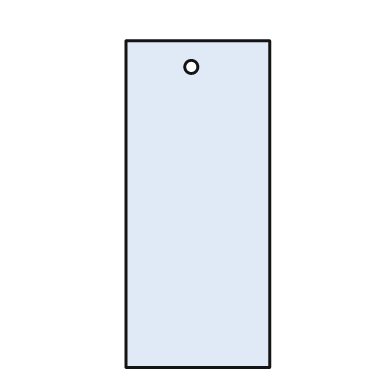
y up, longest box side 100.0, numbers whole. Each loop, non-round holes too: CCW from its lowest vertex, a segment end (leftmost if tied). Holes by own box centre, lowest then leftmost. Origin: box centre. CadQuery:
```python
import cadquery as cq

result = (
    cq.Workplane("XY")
    .moveTo(-22.0, -50.0)
    .lineTo(22.0, -50.0)
    .lineTo(22.0, 50.0)
    .lineTo(-22.0, 50.0)
    .close()
    .moveTo(-2.0, 42.0)
    .circle(2.0)
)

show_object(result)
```